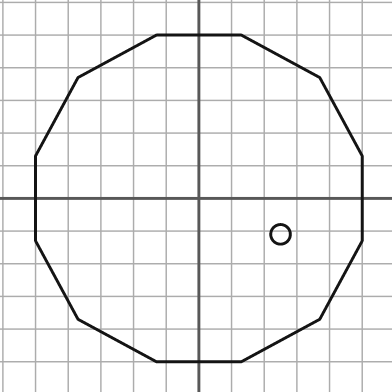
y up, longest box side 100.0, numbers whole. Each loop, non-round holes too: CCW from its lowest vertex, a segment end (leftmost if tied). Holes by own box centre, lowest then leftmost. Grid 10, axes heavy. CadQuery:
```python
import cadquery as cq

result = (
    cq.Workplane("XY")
    .moveTo(-13.0, -50.0)
    .lineTo(13.0, -50.0)
    .lineTo(37.0, -37.0)
    .lineTo(50.0, -13.0)
    .lineTo(50.0, 13.0)
    .lineTo(37.0, 37.0)
    .lineTo(13.0, 50.0)
    .lineTo(-13.0, 50.0)
    .lineTo(-37.0, 37.0)
    .lineTo(-50.0, 13.0)
    .lineTo(-50.0, -13.0)
    .lineTo(-37.0, -37.0)
    .close()
    .moveTo(25.0, -11.0)
    .circle(3.0)
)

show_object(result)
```